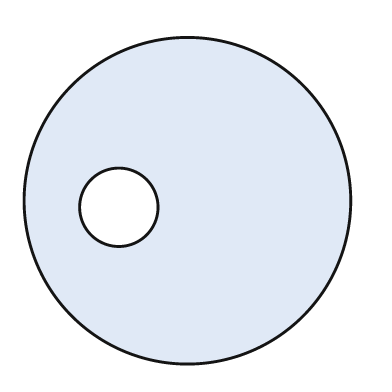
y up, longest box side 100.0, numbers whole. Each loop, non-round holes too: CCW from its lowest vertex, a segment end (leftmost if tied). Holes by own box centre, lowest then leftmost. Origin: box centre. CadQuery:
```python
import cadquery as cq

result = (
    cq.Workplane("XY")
    .moveTo(0.0, 0.0)
    .circle(50.0)
    .moveTo(-21.0, -2.0)
    .circle(12.0)
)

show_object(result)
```